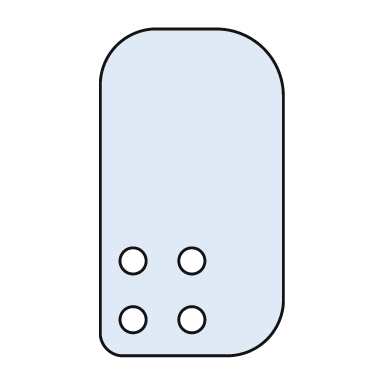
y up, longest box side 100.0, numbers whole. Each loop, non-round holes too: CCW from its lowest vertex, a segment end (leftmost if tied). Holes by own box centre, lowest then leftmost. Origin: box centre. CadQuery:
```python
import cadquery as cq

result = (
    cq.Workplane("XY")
    .moveTo(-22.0, -50.0)
    .lineTo(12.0, -50.0)
    .threePointArc((23.0, -45.0), (28.0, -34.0))
    .lineTo(28.0, 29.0)
    .threePointArc((22.0, 44.0), (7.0, 50.0))
    .lineTo(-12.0, 50.0)
    .threePointArc((-23.0, 45.0), (-28.0, 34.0))
    .lineTo(-28.0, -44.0)
    .threePointArc((-26.0, -48.0), (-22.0, -50.0))
    .close()
    .moveTo(-18.0, -39.0)
    .circle(4.0)
    .moveTo(0.0, -39.0)
    .circle(4.0)
    .moveTo(-18.0, -21.0)
    .circle(4.0)
    .moveTo(0.0, -21.0)
    .circle(4.0)
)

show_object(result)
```